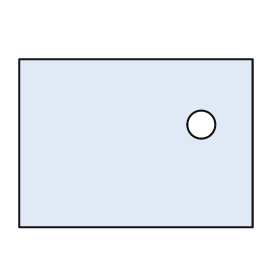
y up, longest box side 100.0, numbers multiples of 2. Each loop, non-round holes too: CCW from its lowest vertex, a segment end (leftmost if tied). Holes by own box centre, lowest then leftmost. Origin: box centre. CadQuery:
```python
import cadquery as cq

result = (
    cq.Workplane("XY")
    .moveTo(-50.0, -36.0)
    .lineTo(50.0, -36.0)
    .lineTo(50.0, 36.0)
    .lineTo(-50.0, 36.0)
    .close()
    .moveTo(28.0, 8.0)
    .circle(6.0)
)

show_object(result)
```